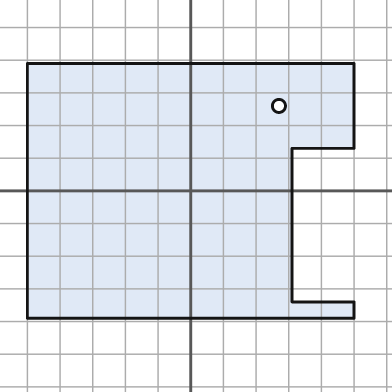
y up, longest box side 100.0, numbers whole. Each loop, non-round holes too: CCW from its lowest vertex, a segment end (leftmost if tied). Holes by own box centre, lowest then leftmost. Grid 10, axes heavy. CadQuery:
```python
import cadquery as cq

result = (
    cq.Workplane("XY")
    .moveTo(-50.0, -39.0)
    .lineTo(50.0, -39.0)
    .lineTo(50.0, -34.0)
    .lineTo(31.0, -34.0)
    .lineTo(31.0, 13.0)
    .lineTo(50.0, 13.0)
    .lineTo(50.0, 39.0)
    .lineTo(-50.0, 39.0)
    .close()
    .moveTo(27.0, 26.0)
    .circle(2.0)
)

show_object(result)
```